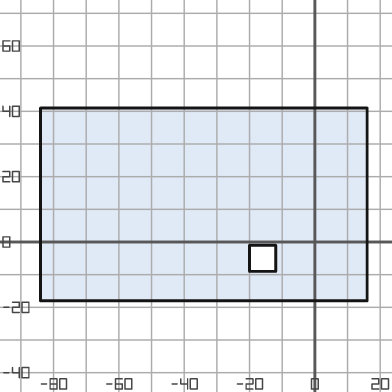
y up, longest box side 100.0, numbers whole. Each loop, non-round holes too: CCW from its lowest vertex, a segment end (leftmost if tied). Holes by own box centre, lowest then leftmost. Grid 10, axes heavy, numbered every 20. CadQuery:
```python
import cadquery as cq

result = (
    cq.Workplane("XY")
    .moveTo(-84.0, -18.0)
    .lineTo(16.0, -18.0)
    .lineTo(16.0, 41.0)
    .lineTo(-84.0, 41.0)
    .close()
    .moveTo(-20.0, -9.0)
    .lineTo(-12.0, -9.0)
    .lineTo(-12.0, -1.0)
    .lineTo(-20.0, -1.0)
    .close()
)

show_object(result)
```